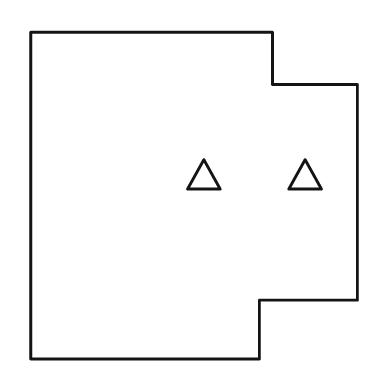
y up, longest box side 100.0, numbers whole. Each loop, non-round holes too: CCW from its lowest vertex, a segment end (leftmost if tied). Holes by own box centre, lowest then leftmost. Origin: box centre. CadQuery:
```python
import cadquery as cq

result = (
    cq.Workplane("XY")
    .moveTo(-50.0, -50.0)
    .lineTo(20.0, -50.0)
    .lineTo(20.0, -32.0)
    .lineTo(50.0, -32.0)
    .lineTo(50.0, 34.0)
    .lineTo(24.0, 34.0)
    .lineTo(24.0, 50.0)
    .lineTo(-50.0, 50.0)
    .close()
    .moveTo(-2.0, 2.0)
    .lineTo(8.0, 2.0)
    .lineTo(3.0, 11.0)
    .close()
    .moveTo(29.0, 2.0)
    .lineTo(39.0, 2.0)
    .lineTo(34.0, 11.0)
    .close()
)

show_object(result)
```